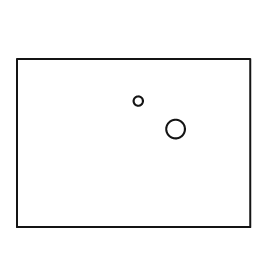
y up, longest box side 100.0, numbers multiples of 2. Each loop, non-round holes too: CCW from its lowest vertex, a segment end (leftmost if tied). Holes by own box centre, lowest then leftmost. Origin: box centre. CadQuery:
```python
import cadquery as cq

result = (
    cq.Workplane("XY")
    .moveTo(-50.0, -36.0)
    .lineTo(50.0, -36.0)
    .lineTo(50.0, 36.0)
    .lineTo(-50.0, 36.0)
    .close()
    .moveTo(18.0, 6.0)
    .circle(4.0)
    .moveTo(2.0, 18.0)
    .circle(2.0)
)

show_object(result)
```